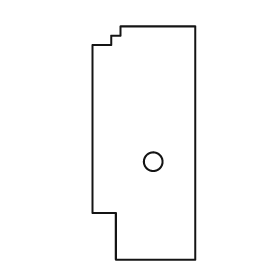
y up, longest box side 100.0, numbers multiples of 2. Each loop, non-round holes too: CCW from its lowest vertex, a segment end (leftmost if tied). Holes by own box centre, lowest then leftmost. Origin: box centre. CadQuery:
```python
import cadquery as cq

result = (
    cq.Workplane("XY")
    .moveTo(-12.0, -50.0)
    .lineTo(22.0, -50.0)
    .lineTo(22.0, 50.0)
    .lineTo(-10.0, 50.0)
    .lineTo(-10.0, 46.0)
    .lineTo(-14.0, 46.0)
    .lineTo(-14.0, 42.0)
    .lineTo(-22.0, 42.0)
    .lineTo(-22.0, -30.0)
    .lineTo(-12.0, -30.0)
    .close()
    .moveTo(4.0, -8.0)
    .circle(4.0)
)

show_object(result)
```